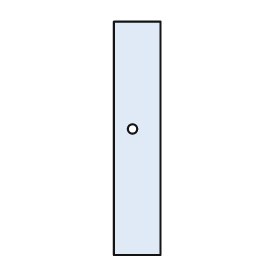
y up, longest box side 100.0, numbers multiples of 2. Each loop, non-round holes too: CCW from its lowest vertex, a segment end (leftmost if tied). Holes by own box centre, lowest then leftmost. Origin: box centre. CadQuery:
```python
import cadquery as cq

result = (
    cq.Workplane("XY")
    .moveTo(-10.0, -50.0)
    .lineTo(10.0, -50.0)
    .lineTo(10.0, 50.0)
    .lineTo(-10.0, 50.0)
    .close()
    .moveTo(-2.0, 4.0)
    .circle(2.0)
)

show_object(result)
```